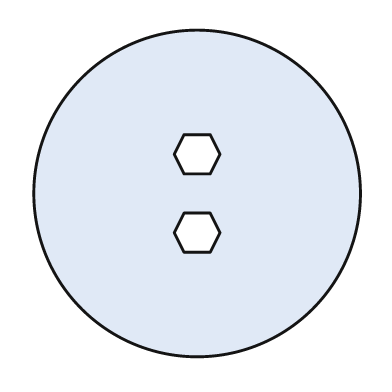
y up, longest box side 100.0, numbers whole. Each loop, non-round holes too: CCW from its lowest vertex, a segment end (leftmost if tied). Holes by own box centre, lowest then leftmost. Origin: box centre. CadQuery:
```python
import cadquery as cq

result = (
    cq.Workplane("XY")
    .moveTo(0.0, 0.0)
    .circle(50.0)
    .moveTo(-4.0, -18.0)
    .lineTo(4.0, -18.0)
    .lineTo(7.0, -12.0)
    .lineTo(4.0, -6.0)
    .lineTo(-4.0, -6.0)
    .lineTo(-7.0, -12.0)
    .close()
    .moveTo(-4.0, 6.0)
    .lineTo(4.0, 6.0)
    .lineTo(7.0, 12.0)
    .lineTo(4.0, 18.0)
    .lineTo(-4.0, 18.0)
    .lineTo(-7.0, 12.0)
    .close()
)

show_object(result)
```